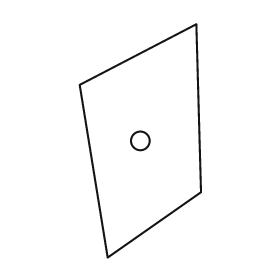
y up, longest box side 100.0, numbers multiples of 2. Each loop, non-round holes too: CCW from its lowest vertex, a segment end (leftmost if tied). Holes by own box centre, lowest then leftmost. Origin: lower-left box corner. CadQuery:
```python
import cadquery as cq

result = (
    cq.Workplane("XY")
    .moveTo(12.0, 0.0)
    .lineTo(52.0, 28.0)
    .lineTo(50.0, 100.0)
    .lineTo(0.0, 74.0)
    .close()
    .moveTo(26.0, 50.0)
    .circle(4.0)
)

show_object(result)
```